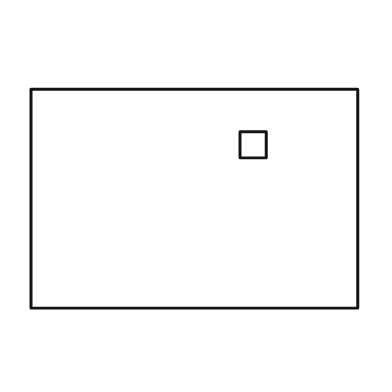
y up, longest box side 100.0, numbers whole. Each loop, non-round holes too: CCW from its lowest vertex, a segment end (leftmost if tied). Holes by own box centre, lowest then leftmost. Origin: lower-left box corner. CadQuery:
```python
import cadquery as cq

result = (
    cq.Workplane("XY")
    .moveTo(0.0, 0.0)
    .lineTo(100.0, 0.0)
    .lineTo(100.0, 67.0)
    .lineTo(0.0, 67.0)
    .close()
    .moveTo(64.0, 46.0)
    .lineTo(72.0, 46.0)
    .lineTo(72.0, 54.0)
    .lineTo(64.0, 54.0)
    .close()
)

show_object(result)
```